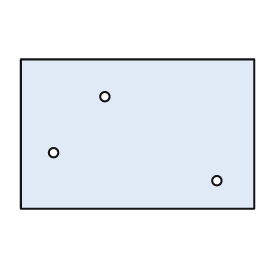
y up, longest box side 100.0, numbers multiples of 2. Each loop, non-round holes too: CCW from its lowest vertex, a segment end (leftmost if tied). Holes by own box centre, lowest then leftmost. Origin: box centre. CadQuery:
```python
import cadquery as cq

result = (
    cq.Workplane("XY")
    .moveTo(-50.0, -32.0)
    .lineTo(50.0, -32.0)
    .lineTo(50.0, 32.0)
    .lineTo(-50.0, 32.0)
    .close()
    .moveTo(34.0, -20.0)
    .circle(2.0)
    .moveTo(-36.0, -8.0)
    .circle(2.0)
    .moveTo(-14.0, 16.0)
    .circle(2.0)
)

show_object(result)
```